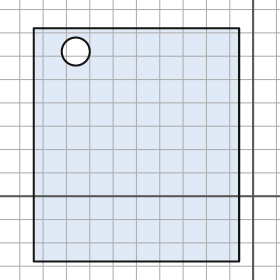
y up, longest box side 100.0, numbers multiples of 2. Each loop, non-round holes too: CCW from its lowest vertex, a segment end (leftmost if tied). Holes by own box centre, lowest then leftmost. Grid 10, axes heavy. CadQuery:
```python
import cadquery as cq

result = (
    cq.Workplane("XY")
    .moveTo(-94.0, -28.0)
    .lineTo(-6.0, -28.0)
    .lineTo(-6.0, 72.0)
    .lineTo(-94.0, 72.0)
    .close()
    .moveTo(-76.0, 62.0)
    .circle(6.0)
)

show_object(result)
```